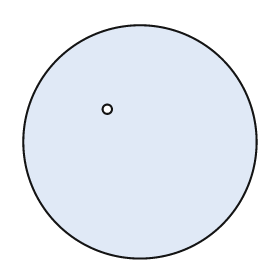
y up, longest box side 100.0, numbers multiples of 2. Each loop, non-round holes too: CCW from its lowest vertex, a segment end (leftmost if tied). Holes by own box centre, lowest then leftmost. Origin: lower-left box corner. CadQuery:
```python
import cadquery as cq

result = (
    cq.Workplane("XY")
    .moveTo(50.0, 50.0)
    .circle(50.0)
    .moveTo(36.0, 64.0)
    .circle(2.0)
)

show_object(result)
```